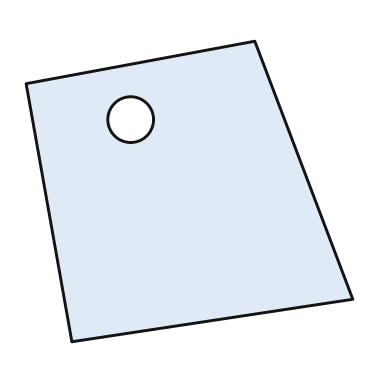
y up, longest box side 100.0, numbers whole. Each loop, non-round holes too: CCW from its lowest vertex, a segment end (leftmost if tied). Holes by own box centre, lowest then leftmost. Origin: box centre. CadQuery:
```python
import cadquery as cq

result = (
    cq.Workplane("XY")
    .moveTo(-36.0, -46.0)
    .lineTo(50.0, -33.0)
    .lineTo(20.0, 46.0)
    .lineTo(-50.0, 33.0)
    .close()
    .moveTo(-18.0, 22.0)
    .circle(7.0)
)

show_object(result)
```